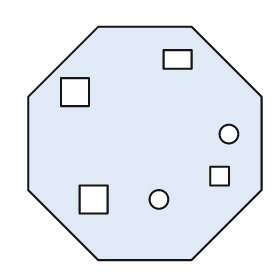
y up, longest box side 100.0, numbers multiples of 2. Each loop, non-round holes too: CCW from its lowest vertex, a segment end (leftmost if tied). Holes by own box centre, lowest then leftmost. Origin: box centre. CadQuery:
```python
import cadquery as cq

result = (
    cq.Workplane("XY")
    .moveTo(-20.0, -50.0)
    .lineTo(20.0, -50.0)
    .lineTo(50.0, -20.0)
    .lineTo(50.0, 20.0)
    .lineTo(20.0, 50.0)
    .lineTo(-20.0, 50.0)
    .lineTo(-50.0, 20.0)
    .lineTo(-50.0, -20.0)
    .close()
    .moveTo(-28.0, -30.0)
    .lineTo(-16.0, -30.0)
    .lineTo(-16.0, -18.0)
    .lineTo(-28.0, -18.0)
    .close()
    .moveTo(6.0, -24.0)
    .circle(4.0)
    .moveTo(28.0, -18.0)
    .lineTo(36.0, -18.0)
    .lineTo(36.0, -10.0)
    .lineTo(28.0, -10.0)
    .close()
    .moveTo(36.0, 4.0)
    .circle(4.0)
    .moveTo(-36.0, 16.0)
    .lineTo(-24.0, 16.0)
    .lineTo(-24.0, 28.0)
    .lineTo(-36.0, 28.0)
    .close()
    .moveTo(8.0, 32.0)
    .lineTo(20.0, 32.0)
    .lineTo(20.0, 40.0)
    .lineTo(8.0, 40.0)
    .close()
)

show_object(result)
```